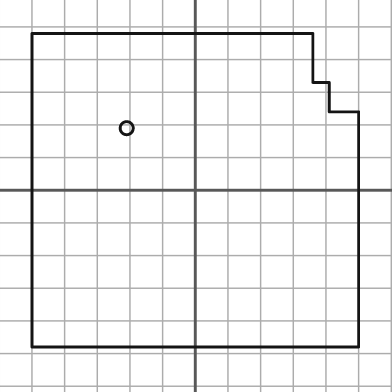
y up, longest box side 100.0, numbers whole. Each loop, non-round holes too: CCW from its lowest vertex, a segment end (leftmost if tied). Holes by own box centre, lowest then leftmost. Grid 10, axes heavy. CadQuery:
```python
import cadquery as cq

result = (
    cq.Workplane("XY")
    .moveTo(-50.0, -48.0)
    .lineTo(50.0, -48.0)
    .lineTo(50.0, 24.0)
    .lineTo(41.0, 24.0)
    .lineTo(41.0, 33.0)
    .lineTo(36.0, 33.0)
    .lineTo(36.0, 48.0)
    .lineTo(-50.0, 48.0)
    .close()
    .moveTo(-21.0, 19.0)
    .circle(2.0)
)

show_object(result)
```